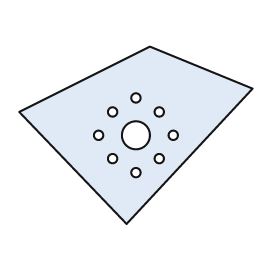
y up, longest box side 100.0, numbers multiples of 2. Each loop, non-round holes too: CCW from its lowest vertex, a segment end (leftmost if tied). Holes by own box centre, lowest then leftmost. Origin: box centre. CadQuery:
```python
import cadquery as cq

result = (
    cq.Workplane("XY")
    .moveTo(-4.0, -38.0)
    .lineTo(50.0, 20.0)
    .lineTo(6.0, 38.0)
    .lineTo(-50.0, 10.0)
    .close()
    .moveTo(0.0, -16.0)
    .circle(2.0)
    .moveTo(-10.0, -10.0)
    .circle(2.0)
    .moveTo(10.0, -10.0)
    .circle(2.0)
    .moveTo(-16.0, 0.0)
    .circle(2.0)
    .moveTo(0.0, 0.0)
    .circle(6.0)
    .moveTo(16.0, 0.0)
    .circle(2.0)
    .moveTo(-10.0, 10.0)
    .circle(2.0)
    .moveTo(10.0, 10.0)
    .circle(2.0)
    .moveTo(0.0, 16.0)
    .circle(2.0)
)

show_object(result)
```